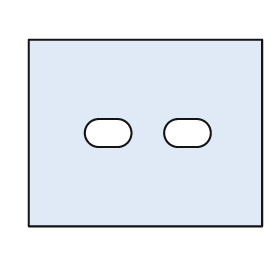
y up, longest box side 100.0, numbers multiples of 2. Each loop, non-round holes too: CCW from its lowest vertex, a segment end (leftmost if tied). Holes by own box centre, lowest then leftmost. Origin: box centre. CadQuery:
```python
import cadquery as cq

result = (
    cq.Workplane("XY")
    .moveTo(-50.0, -40.0)
    .lineTo(50.0, -40.0)
    .lineTo(50.0, 40.0)
    .lineTo(-50.0, 40.0)
    .close()
    .moveTo(-20.0, -6.0)
    .lineTo(-12.0, -6.0)
    .threePointArc((-6.0, 0.0), (-12.0, 6.0))
    .lineTo(-20.0, 6.0)
    .threePointArc((-26.0, 0.0), (-20.0, -6.0))
    .close()
    .moveTo(14.0, -6.0)
    .lineTo(22.0, -6.0)
    .threePointArc((28.0, 0.0), (22.0, 6.0))
    .lineTo(14.0, 6.0)
    .threePointArc((8.0, 0.0), (14.0, -6.0))
    .close()
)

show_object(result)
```